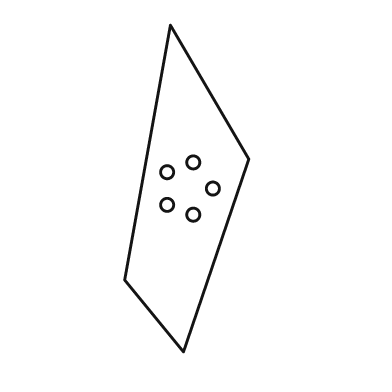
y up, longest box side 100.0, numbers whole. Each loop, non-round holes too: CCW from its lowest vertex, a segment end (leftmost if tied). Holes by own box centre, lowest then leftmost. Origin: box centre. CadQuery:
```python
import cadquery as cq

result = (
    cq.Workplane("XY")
    .moveTo(-1.0, -50.0)
    .lineTo(19.0, 9.0)
    .lineTo(-5.0, 50.0)
    .lineTo(-19.0, -28.0)
    .close()
    .moveTo(2.0, -8.0)
    .circle(2.0)
    .moveTo(-6.0, -5.0)
    .circle(2.0)
    .moveTo(8.0, 0.0)
    .circle(2.0)
    .moveTo(-6.0, 5.0)
    .circle(2.0)
    .moveTo(2.0, 8.0)
    .circle(2.0)
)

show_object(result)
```